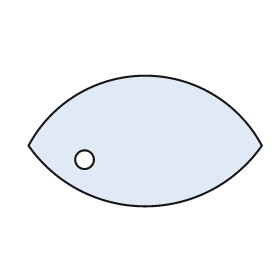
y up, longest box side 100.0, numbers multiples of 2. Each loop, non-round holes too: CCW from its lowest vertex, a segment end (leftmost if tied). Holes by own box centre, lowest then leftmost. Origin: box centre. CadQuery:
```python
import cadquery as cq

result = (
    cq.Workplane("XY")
    .moveTo(-50.0, -2.0)
    .threePointArc((0.0, -28.0), (50.0, -2.0))
    .threePointArc((0.0, 28.0), (-50.0, -2.0))
    .close()
    .moveTo(-26.0, -8.0)
    .circle(4.0)
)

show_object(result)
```